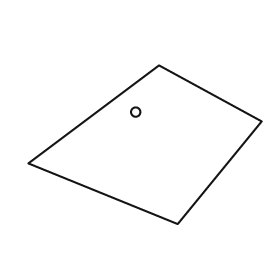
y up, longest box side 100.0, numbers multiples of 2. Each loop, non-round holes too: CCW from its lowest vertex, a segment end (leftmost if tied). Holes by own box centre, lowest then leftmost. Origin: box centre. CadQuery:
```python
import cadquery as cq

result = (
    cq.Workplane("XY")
    .moveTo(14.0, -34.0)
    .lineTo(50.0, 10.0)
    .lineTo(6.0, 34.0)
    .lineTo(-50.0, -8.0)
    .close()
    .moveTo(-4.0, 14.0)
    .circle(2.0)
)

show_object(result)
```